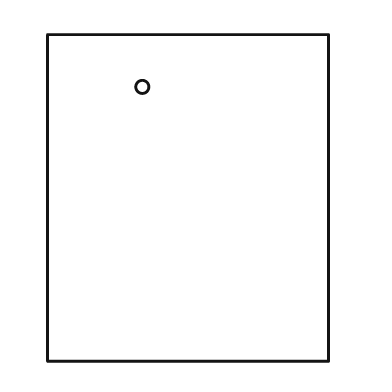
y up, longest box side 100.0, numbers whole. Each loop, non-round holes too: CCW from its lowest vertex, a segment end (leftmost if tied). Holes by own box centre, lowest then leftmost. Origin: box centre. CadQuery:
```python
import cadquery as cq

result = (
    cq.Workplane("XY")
    .moveTo(-43.0, -50.0)
    .lineTo(43.0, -50.0)
    .lineTo(43.0, 50.0)
    .lineTo(-43.0, 50.0)
    .close()
    .moveTo(-14.0, 34.0)
    .circle(2.0)
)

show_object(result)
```